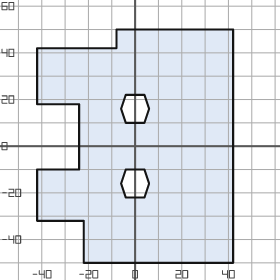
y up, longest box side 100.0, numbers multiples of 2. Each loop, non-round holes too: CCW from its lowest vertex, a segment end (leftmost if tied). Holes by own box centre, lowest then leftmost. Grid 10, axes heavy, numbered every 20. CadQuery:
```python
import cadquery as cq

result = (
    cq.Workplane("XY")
    .moveTo(-22.0, -50.0)
    .lineTo(42.0, -50.0)
    .lineTo(42.0, 50.0)
    .lineTo(-8.0, 50.0)
    .lineTo(-8.0, 42.0)
    .lineTo(-42.0, 42.0)
    .lineTo(-42.0, 18.0)
    .lineTo(-24.0, 18.0)
    .lineTo(-24.0, -10.0)
    .lineTo(-42.0, -10.0)
    .lineTo(-42.0, -32.0)
    .lineTo(-22.0, -32.0)
    .close()
    .moveTo(-4.0, -22.0)
    .lineTo(4.0, -22.0)
    .lineTo(6.0, -16.0)
    .lineTo(4.0, -10.0)
    .lineTo(-4.0, -10.0)
    .lineTo(-6.0, -16.0)
    .close()
    .moveTo(-4.0, 10.0)
    .lineTo(4.0, 10.0)
    .lineTo(6.0, 16.0)
    .lineTo(4.0, 22.0)
    .lineTo(-4.0, 22.0)
    .lineTo(-6.0, 16.0)
    .close()
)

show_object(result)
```